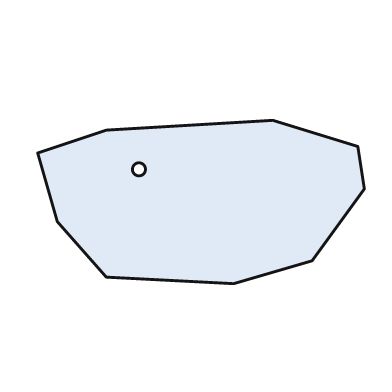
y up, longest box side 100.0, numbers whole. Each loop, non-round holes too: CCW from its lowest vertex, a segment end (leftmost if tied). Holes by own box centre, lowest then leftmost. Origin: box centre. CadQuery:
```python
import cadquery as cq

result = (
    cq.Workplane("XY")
    .moveTo(10.0, -25.0)
    .lineTo(34.0, -18.0)
    .lineTo(50.0, 4.0)
    .lineTo(48.0, 17.0)
    .lineTo(22.0, 25.0)
    .lineTo(-29.0, 22.0)
    .lineTo(-50.0, 15.0)
    .lineTo(-44.0, -6.0)
    .lineTo(-29.0, -23.0)
    .close()
    .moveTo(-19.0, 10.0)
    .circle(2.0)
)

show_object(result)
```